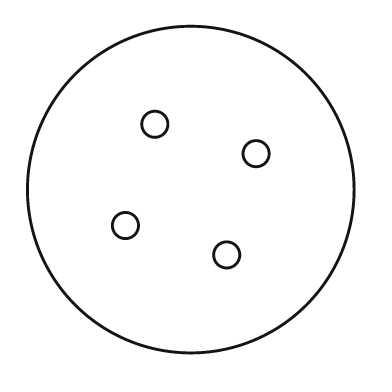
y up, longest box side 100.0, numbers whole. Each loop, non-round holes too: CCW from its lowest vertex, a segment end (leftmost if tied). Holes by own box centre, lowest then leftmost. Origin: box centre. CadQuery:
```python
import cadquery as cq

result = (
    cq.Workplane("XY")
    .moveTo(0.0, 0.0)
    .circle(50.0)
    .moveTo(11.0, -20.0)
    .circle(4.0)
    .moveTo(-20.0, -11.0)
    .circle(4.0)
    .moveTo(20.0, 11.0)
    .circle(4.0)
    .moveTo(-11.0, 20.0)
    .circle(4.0)
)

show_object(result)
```